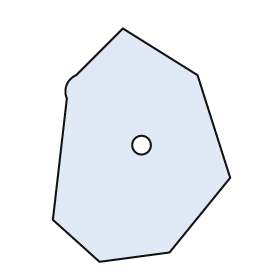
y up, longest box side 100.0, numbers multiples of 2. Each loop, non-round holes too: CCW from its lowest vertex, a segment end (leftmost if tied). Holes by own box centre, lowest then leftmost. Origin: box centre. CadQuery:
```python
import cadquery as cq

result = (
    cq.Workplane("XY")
    .moveTo(-18.0, -50.0)
    .lineTo(12.0, -46.0)
    .lineTo(38.0, -14.0)
    .lineTo(24.0, 30.0)
    .lineTo(-8.0, 50.0)
    .lineTo(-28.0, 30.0)
    .threePointArc((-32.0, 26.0), (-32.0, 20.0))
    .lineTo(-38.0, -32.0)
    .close()
    .moveTo(0.0, 0.0)
    .circle(4.0)
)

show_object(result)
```